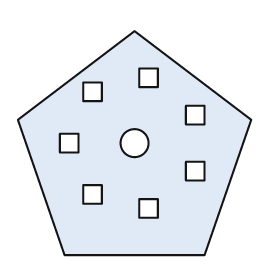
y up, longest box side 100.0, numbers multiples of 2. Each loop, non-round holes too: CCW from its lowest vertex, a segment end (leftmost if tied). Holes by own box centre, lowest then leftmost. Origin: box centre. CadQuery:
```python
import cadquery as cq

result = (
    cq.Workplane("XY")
    .moveTo(-30.0, -48.0)
    .lineTo(30.0, -48.0)
    .lineTo(50.0, 10.0)
    .lineTo(0.0, 48.0)
    .lineTo(-50.0, 10.0)
    .close()
    .moveTo(2.0, -32.0)
    .lineTo(10.0, -32.0)
    .lineTo(10.0, -24.0)
    .lineTo(2.0, -24.0)
    .close()
    .moveTo(-22.0, -26.0)
    .lineTo(-14.0, -26.0)
    .lineTo(-14.0, -18.0)
    .lineTo(-22.0, -18.0)
    .close()
    .moveTo(22.0, -16.0)
    .lineTo(30.0, -16.0)
    .lineTo(30.0, -8.0)
    .lineTo(22.0, -8.0)
    .close()
    .moveTo(-32.0, -4.0)
    .lineTo(-24.0, -4.0)
    .lineTo(-24.0, 4.0)
    .lineTo(-32.0, 4.0)
    .close()
    .moveTo(0.0, 0.0)
    .circle(6.0)
    .moveTo(22.0, 8.0)
    .lineTo(30.0, 8.0)
    .lineTo(30.0, 16.0)
    .lineTo(22.0, 16.0)
    .close()
    .moveTo(-22.0, 18.0)
    .lineTo(-14.0, 18.0)
    .lineTo(-14.0, 26.0)
    .lineTo(-22.0, 26.0)
    .close()
    .moveTo(2.0, 24.0)
    .lineTo(10.0, 24.0)
    .lineTo(10.0, 32.0)
    .lineTo(2.0, 32.0)
    .close()
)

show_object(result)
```